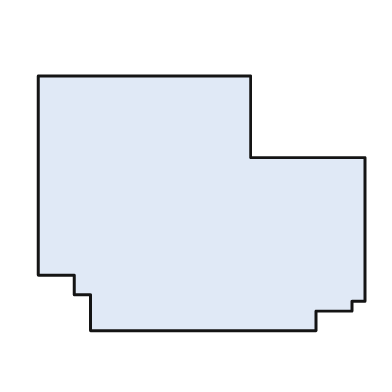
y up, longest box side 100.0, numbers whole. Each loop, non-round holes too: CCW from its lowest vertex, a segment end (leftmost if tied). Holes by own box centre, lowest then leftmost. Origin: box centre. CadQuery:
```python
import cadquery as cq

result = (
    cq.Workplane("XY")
    .moveTo(-34.0, -39.0)
    .lineTo(35.0, -39.0)
    .lineTo(35.0, -33.0)
    .lineTo(46.0, -33.0)
    .lineTo(46.0, -30.0)
    .lineTo(50.0, -30.0)
    .lineTo(50.0, 14.0)
    .lineTo(15.0, 14.0)
    .lineTo(15.0, 39.0)
    .lineTo(-50.0, 39.0)
    .lineTo(-50.0, -22.0)
    .lineTo(-39.0, -22.0)
    .lineTo(-39.0, -28.0)
    .lineTo(-34.0, -28.0)
    .close()
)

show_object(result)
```